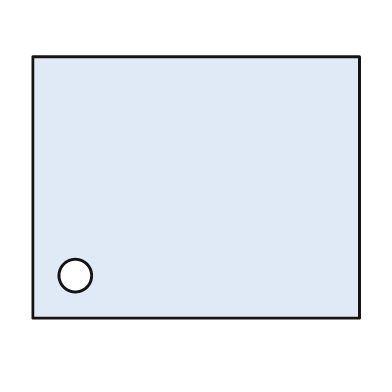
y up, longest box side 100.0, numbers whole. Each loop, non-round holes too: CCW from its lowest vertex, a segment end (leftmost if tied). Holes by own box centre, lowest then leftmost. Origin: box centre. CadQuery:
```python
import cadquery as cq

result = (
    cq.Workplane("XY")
    .moveTo(-50.0, -40.0)
    .lineTo(50.0, -40.0)
    .lineTo(50.0, 40.0)
    .lineTo(-50.0, 40.0)
    .close()
    .moveTo(-37.0, -27.0)
    .circle(5.0)
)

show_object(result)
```